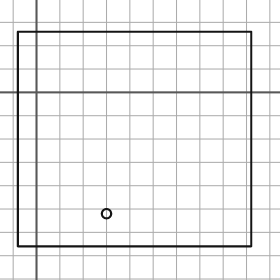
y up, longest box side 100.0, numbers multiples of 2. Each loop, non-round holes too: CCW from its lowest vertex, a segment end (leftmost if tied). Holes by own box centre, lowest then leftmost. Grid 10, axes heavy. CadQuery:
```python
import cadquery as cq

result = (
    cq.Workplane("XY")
    .moveTo(-8.0, -66.0)
    .lineTo(92.0, -66.0)
    .lineTo(92.0, 26.0)
    .lineTo(-8.0, 26.0)
    .close()
    .moveTo(30.0, -52.0)
    .circle(2.0)
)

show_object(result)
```